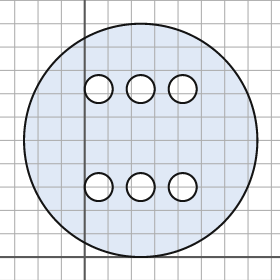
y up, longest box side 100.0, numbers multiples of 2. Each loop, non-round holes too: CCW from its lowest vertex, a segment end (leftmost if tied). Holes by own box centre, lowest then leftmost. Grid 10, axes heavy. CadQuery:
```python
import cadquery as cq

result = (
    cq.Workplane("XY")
    .moveTo(24.0, 50.0)
    .circle(50.0)
    .moveTo(6.0, 30.0)
    .circle(6.0)
    .moveTo(24.0, 30.0)
    .circle(6.0)
    .moveTo(42.0, 30.0)
    .circle(6.0)
    .moveTo(6.0, 72.0)
    .circle(6.0)
    .moveTo(24.0, 72.0)
    .circle(6.0)
    .moveTo(42.0, 72.0)
    .circle(6.0)
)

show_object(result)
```